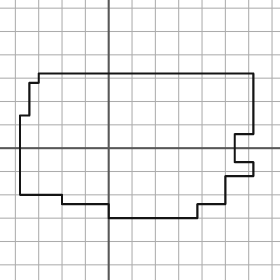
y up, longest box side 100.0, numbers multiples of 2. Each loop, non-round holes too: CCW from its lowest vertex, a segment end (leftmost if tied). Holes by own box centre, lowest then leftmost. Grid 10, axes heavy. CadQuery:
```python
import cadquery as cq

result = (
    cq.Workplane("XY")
    .moveTo(0.0, -30.0)
    .lineTo(38.0, -30.0)
    .lineTo(38.0, -24.0)
    .lineTo(50.0, -24.0)
    .lineTo(50.0, -12.0)
    .lineTo(62.0, -12.0)
    .lineTo(62.0, -6.0)
    .lineTo(54.0, -6.0)
    .lineTo(54.0, 6.0)
    .lineTo(62.0, 6.0)
    .lineTo(62.0, 32.0)
    .lineTo(-30.0, 32.0)
    .lineTo(-30.0, 28.0)
    .lineTo(-34.0, 28.0)
    .lineTo(-34.0, 14.0)
    .lineTo(-38.0, 14.0)
    .lineTo(-38.0, -20.0)
    .lineTo(-20.0, -20.0)
    .lineTo(-20.0, -24.0)
    .lineTo(0.0, -24.0)
    .close()
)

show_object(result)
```